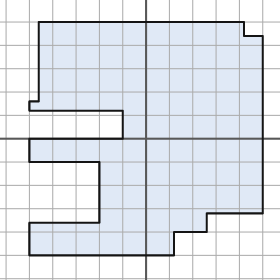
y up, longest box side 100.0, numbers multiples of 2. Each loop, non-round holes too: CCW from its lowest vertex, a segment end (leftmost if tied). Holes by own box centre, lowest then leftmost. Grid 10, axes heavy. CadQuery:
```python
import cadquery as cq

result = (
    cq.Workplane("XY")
    .moveTo(-50.0, -50.0)
    .lineTo(12.0, -50.0)
    .lineTo(12.0, -40.0)
    .lineTo(26.0, -40.0)
    .lineTo(26.0, -32.0)
    .lineTo(50.0, -32.0)
    .lineTo(50.0, 44.0)
    .lineTo(42.0, 44.0)
    .lineTo(42.0, 50.0)
    .lineTo(-46.0, 50.0)
    .lineTo(-46.0, 16.0)
    .lineTo(-50.0, 16.0)
    .lineTo(-50.0, 12.0)
    .lineTo(-10.0, 12.0)
    .lineTo(-10.0, 0.0)
    .lineTo(-50.0, 0.0)
    .lineTo(-50.0, -10.0)
    .lineTo(-20.0, -10.0)
    .lineTo(-20.0, -36.0)
    .lineTo(-50.0, -36.0)
    .close()
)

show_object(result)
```